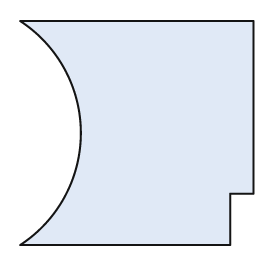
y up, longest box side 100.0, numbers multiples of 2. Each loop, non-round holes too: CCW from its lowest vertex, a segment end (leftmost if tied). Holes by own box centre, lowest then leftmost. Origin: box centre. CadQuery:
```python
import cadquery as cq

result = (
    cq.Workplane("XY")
    .moveTo(-50.0, -48.0)
    .lineTo(40.0, -48.0)
    .lineTo(40.0, -26.0)
    .lineTo(50.0, -26.0)
    .lineTo(50.0, 48.0)
    .lineTo(-50.0, 48.0)
    .threePointArc((-24.0, 0.0), (-50.0, -48.0))
    .close()
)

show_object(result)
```